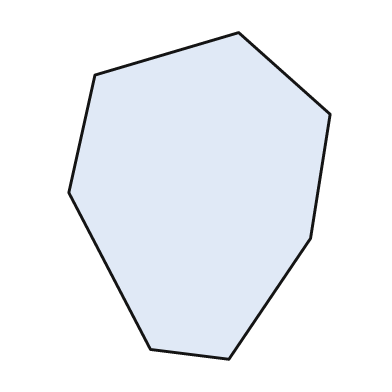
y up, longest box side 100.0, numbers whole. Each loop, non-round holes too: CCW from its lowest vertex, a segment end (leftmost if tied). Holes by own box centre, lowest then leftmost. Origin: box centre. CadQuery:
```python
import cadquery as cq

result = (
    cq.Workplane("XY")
    .moveTo(9.0, -50.0)
    .lineTo(34.0, -13.0)
    .lineTo(40.0, 25.0)
    .lineTo(12.0, 50.0)
    .lineTo(-32.0, 37.0)
    .lineTo(-40.0, 1.0)
    .lineTo(-15.0, -47.0)
    .close()
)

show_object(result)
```